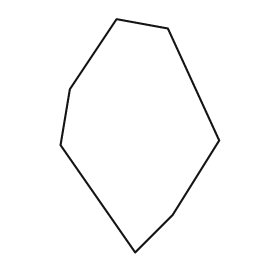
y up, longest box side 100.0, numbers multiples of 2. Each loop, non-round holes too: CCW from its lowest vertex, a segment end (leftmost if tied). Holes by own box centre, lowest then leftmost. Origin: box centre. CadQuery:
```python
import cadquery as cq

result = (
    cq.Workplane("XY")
    .moveTo(-2.0, -50.0)
    .lineTo(14.0, -34.0)
    .lineTo(34.0, -2.0)
    .lineTo(12.0, 46.0)
    .lineTo(-10.0, 50.0)
    .lineTo(-30.0, 20.0)
    .lineTo(-34.0, -4.0)
    .close()
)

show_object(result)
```